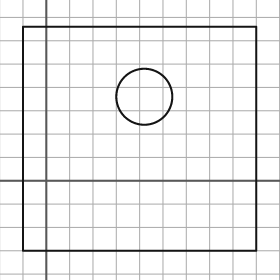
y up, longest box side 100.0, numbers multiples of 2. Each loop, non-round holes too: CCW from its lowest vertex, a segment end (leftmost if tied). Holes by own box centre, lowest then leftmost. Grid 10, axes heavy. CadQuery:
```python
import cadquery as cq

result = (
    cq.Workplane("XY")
    .moveTo(-10.0, -30.0)
    .lineTo(90.0, -30.0)
    .lineTo(90.0, 66.0)
    .lineTo(-10.0, 66.0)
    .close()
    .moveTo(42.0, 36.0)
    .circle(12.0)
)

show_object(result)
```